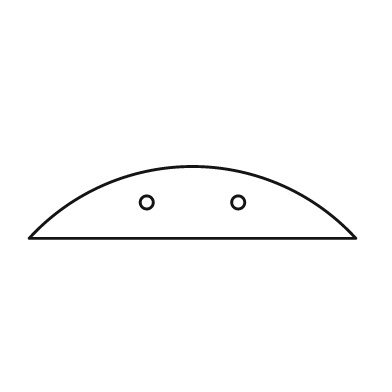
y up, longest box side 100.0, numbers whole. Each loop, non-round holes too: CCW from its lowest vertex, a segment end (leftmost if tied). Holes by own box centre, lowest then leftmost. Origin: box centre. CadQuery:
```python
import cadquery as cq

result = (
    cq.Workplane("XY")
    .moveTo(-50.0, -11.0)
    .lineTo(50.0, -11.0)
    .threePointArc((0.0, 11.0), (-50.0, -11.0))
    .close()
    .moveTo(-14.0, 0.0)
    .circle(2.0)
    .moveTo(14.0, 0.0)
    .circle(2.0)
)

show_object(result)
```